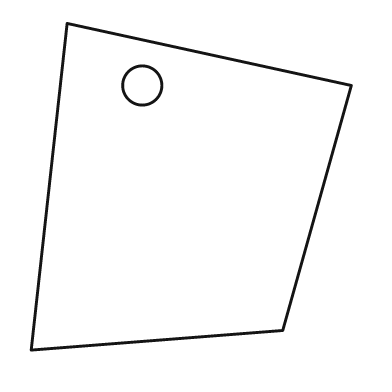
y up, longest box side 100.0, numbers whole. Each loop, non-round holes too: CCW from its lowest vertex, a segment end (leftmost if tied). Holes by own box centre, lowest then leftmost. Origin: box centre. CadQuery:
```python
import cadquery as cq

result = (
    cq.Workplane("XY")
    .moveTo(-49.0, -50.0)
    .lineTo(28.0, -44.0)
    .lineTo(49.0, 31.0)
    .lineTo(-38.0, 50.0)
    .close()
    .moveTo(-15.0, 31.0)
    .circle(6.0)
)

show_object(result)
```